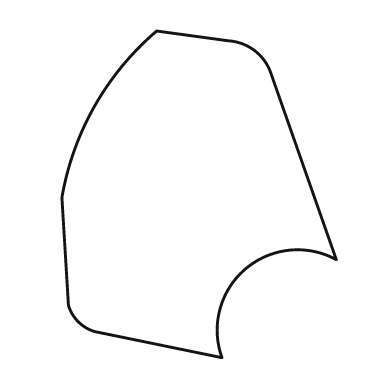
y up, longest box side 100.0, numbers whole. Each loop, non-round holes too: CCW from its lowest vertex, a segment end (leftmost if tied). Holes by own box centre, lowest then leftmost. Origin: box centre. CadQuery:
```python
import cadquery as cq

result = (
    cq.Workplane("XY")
    .moveTo(7.0, -50.0)
    .threePointArc((14.0, -23.0), (42.0, -20.0))
    .lineTo(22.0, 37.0)
    .threePointArc((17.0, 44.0), (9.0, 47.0))
    .lineTo(-13.0, 50.0)
    .threePointArc((-32.0, 27.0), (-42.0, -1.0))
    .lineTo(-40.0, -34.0)
    .threePointArc((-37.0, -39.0), (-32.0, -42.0))
    .close()
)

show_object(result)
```